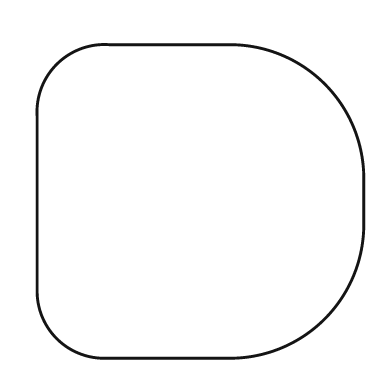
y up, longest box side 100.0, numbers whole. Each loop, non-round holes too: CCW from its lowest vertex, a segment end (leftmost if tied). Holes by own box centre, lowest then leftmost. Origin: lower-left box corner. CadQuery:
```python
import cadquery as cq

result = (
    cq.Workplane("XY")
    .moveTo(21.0, 0.0)
    .lineTo(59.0, 0.0)
    .threePointArc((88.0, 12.0), (100.0, 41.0))
    .lineTo(100.0, 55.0)
    .threePointArc((88.0, 84.0), (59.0, 96.0))
    .lineTo(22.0, 96.0)
    .threePointArc((6.0, 90.0), (0.0, 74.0))
    .lineTo(0.0, 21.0)
    .threePointArc((6.0, 6.0), (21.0, 0.0))
    .close()
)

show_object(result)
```